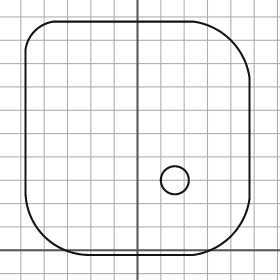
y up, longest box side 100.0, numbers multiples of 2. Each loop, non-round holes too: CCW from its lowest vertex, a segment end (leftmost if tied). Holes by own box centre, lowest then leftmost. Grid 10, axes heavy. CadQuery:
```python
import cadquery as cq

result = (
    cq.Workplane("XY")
    .moveTo(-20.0, -2.0)
    .lineTo(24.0, -2.0)
    .threePointArc((40.0, 6.0), (48.0, 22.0))
    .lineTo(48.0, 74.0)
    .threePointArc((40.0, 90.0), (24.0, 98.0))
    .lineTo(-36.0, 98.0)
    .threePointArc((-44.0, 94.0), (-48.0, 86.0))
    .lineTo(-48.0, 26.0)
    .threePointArc((-40.0, 6.0), (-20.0, -2.0))
    .close()
    .moveTo(16.0, 30.0)
    .circle(6.0)
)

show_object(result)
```